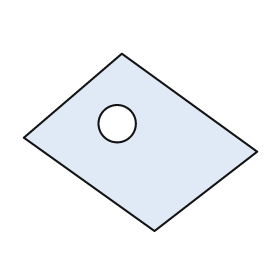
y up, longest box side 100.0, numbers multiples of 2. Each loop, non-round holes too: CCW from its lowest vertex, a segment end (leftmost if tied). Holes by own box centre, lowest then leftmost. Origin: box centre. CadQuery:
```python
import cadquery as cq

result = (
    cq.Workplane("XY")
    .moveTo(6.0, -38.0)
    .lineTo(50.0, -4.0)
    .lineTo(-8.0, 38.0)
    .lineTo(-50.0, 2.0)
    .close()
    .moveTo(-10.0, 8.0)
    .circle(8.0)
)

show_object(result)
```